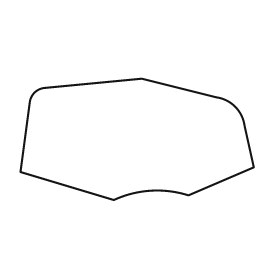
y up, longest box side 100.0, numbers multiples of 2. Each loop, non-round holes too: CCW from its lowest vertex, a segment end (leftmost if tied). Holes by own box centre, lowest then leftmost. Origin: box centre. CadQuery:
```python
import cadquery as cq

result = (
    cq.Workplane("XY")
    .moveTo(-10.0, -26.0)
    .threePointArc((6.0, -22.0), (22.0, -24.0))
    .lineTo(50.0, -12.0)
    .lineTo(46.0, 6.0)
    .threePointArc((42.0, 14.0), (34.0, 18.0))
    .lineTo(2.0, 26.0)
    .lineTo(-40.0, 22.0)
    .threePointArc((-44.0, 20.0), (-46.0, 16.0))
    .lineTo(-50.0, -14.0)
    .close()
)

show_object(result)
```